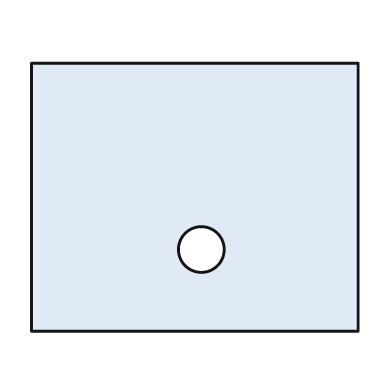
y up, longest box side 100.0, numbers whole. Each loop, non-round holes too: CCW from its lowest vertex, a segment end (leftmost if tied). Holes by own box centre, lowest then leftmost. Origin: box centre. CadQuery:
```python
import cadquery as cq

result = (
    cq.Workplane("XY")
    .moveTo(-50.0, -41.0)
    .lineTo(50.0, -41.0)
    .lineTo(50.0, 41.0)
    .lineTo(-50.0, 41.0)
    .close()
    .moveTo(2.0, -16.0)
    .circle(7.0)
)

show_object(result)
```